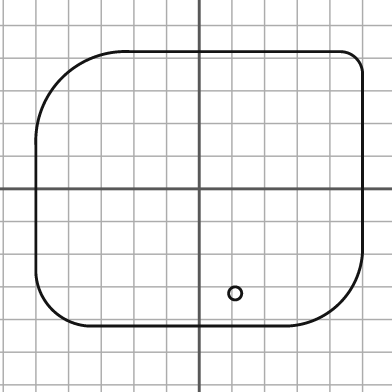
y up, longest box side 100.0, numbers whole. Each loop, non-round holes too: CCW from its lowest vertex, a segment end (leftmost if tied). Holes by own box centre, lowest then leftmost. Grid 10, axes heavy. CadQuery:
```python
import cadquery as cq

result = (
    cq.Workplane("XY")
    .moveTo(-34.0, -42.0)
    .lineTo(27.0, -42.0)
    .threePointArc((43.0, -35.0), (50.0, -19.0))
    .lineTo(50.0, 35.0)
    .threePointArc((48.0, 40.0), (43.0, 42.0))
    .lineTo(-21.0, 42.0)
    .threePointArc((-42.0, 34.0), (-50.0, 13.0))
    .lineTo(-50.0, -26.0)
    .threePointArc((-45.0, -37.0), (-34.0, -42.0))
    .close()
    .moveTo(11.0, -32.0)
    .circle(2.0)
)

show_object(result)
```